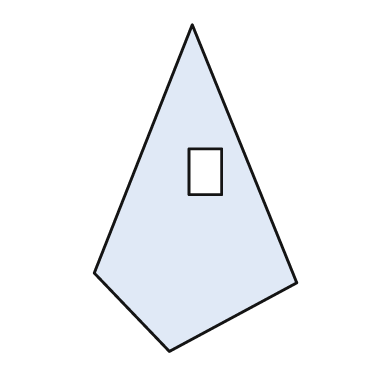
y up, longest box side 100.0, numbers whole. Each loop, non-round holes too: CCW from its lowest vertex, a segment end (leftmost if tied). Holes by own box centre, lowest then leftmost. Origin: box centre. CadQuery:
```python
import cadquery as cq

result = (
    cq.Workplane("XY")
    .moveTo(-8.0, -50.0)
    .lineTo(31.0, -29.0)
    .lineTo(-1.0, 50.0)
    .lineTo(-31.0, -26.0)
    .close()
    .moveTo(-2.0, -2.0)
    .lineTo(8.0, -2.0)
    .lineTo(8.0, 12.0)
    .lineTo(-2.0, 12.0)
    .close()
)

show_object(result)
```